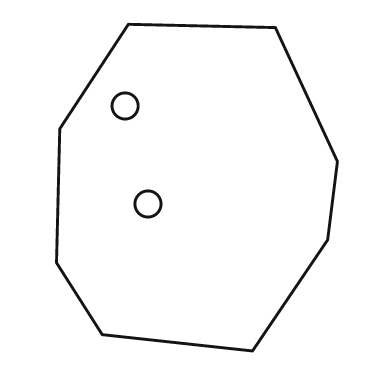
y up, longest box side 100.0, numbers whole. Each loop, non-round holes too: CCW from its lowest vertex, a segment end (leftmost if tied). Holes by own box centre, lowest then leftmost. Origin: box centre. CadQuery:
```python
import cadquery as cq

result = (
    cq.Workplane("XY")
    .moveTo(17.0, -50.0)
    .lineTo(40.0, -16.0)
    .lineTo(43.0, 8.0)
    .lineTo(24.0, 49.0)
    .lineTo(-21.0, 50.0)
    .lineTo(-42.0, 18.0)
    .lineTo(-43.0, -23.0)
    .lineTo(-29.0, -45.0)
    .close()
    .moveTo(-15.0, -5.0)
    .circle(4.0)
    .moveTo(-22.0, 25.0)
    .circle(4.0)
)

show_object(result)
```